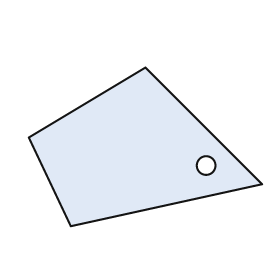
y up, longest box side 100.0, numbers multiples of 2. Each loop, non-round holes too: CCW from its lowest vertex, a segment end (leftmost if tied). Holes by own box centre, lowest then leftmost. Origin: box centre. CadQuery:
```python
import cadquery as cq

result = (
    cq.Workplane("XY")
    .moveTo(-32.0, -34.0)
    .lineTo(50.0, -16.0)
    .lineTo(0.0, 34.0)
    .lineTo(-50.0, 4.0)
    .close()
    .moveTo(26.0, -8.0)
    .circle(4.0)
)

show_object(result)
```